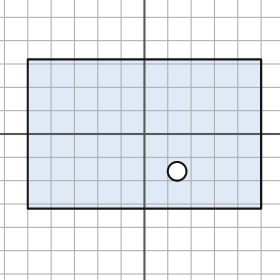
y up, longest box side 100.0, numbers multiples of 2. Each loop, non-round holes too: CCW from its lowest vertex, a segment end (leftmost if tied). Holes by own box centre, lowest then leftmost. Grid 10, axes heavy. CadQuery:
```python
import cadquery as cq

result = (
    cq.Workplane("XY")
    .moveTo(-50.0, -32.0)
    .lineTo(50.0, -32.0)
    .lineTo(50.0, 32.0)
    .lineTo(-50.0, 32.0)
    .close()
    .moveTo(14.0, -16.0)
    .circle(4.0)
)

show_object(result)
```